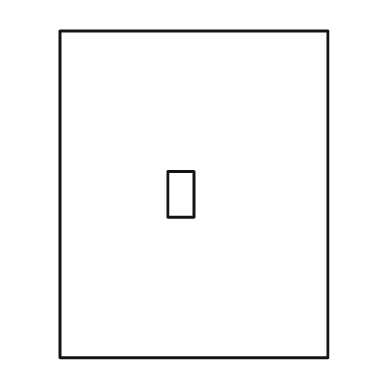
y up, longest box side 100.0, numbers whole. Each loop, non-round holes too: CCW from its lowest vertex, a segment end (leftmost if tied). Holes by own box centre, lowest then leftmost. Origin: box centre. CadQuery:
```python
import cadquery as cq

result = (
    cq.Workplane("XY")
    .moveTo(-41.0, -50.0)
    .lineTo(41.0, -50.0)
    .lineTo(41.0, 50.0)
    .lineTo(-41.0, 50.0)
    .close()
    .moveTo(-8.0, -7.0)
    .lineTo(0.0, -7.0)
    .lineTo(0.0, 7.0)
    .lineTo(-8.0, 7.0)
    .close()
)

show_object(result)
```